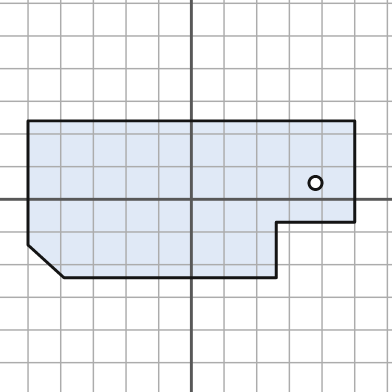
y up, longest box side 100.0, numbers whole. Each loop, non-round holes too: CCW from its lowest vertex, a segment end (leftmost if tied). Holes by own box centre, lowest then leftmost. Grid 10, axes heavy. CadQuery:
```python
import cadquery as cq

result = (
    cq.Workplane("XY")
    .moveTo(-39.0, -24.0)
    .lineTo(26.0, -24.0)
    .lineTo(26.0, -7.0)
    .lineTo(50.0, -7.0)
    .lineTo(50.0, 24.0)
    .lineTo(-50.0, 24.0)
    .lineTo(-50.0, -14.0)
    .close()
    .moveTo(38.0, 5.0)
    .circle(2.0)
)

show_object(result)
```